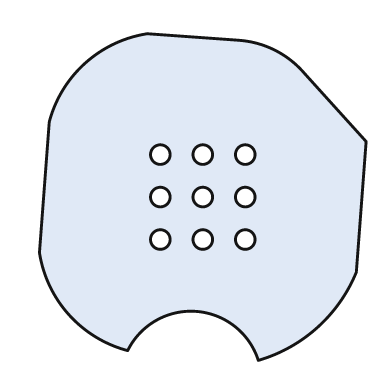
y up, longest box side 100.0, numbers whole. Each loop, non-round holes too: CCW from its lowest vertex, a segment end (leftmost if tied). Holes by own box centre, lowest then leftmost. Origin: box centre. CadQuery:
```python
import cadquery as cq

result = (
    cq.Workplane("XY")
    .moveTo(17.0, -50.0)
    .threePointArc((35.0, -40.0), (47.0, -23.0))
    .lineTo(50.0, 17.0)
    .lineTo(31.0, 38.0)
    .threePointArc((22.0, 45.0), (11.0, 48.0))
    .lineTo(-17.0, 50.0)
    .threePointArc((-36.0, 41.0), (-47.0, 23.0))
    .lineTo(-50.0, -17.0)
    .threePointArc((-41.0, -36.0), (-23.0, -47.0))
    .threePointArc((-2.0, -35.0), (17.0, -50.0))
    .close()
    .moveTo(-13.0, -13.0)
    .circle(3.0)
    .moveTo(0.0, -13.0)
    .circle(3.0)
    .moveTo(13.0, -13.0)
    .circle(3.0)
    .moveTo(-13.0, 0.0)
    .circle(3.0)
    .moveTo(0.0, 0.0)
    .circle(3.0)
    .moveTo(13.0, 0.0)
    .circle(3.0)
    .moveTo(-13.0, 13.0)
    .circle(3.0)
    .moveTo(0.0, 13.0)
    .circle(3.0)
    .moveTo(13.0, 13.0)
    .circle(3.0)
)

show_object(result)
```